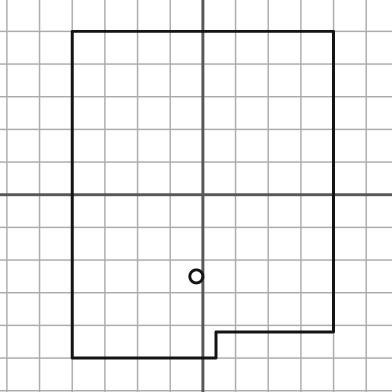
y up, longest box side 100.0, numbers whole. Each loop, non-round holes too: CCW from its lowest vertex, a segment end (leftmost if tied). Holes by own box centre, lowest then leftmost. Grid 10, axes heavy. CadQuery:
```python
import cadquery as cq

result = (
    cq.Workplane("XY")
    .moveTo(-40.0, -50.0)
    .lineTo(4.0, -50.0)
    .lineTo(4.0, -42.0)
    .lineTo(40.0, -42.0)
    .lineTo(40.0, 50.0)
    .lineTo(-40.0, 50.0)
    .close()
    .moveTo(-2.0, -25.0)
    .circle(2.0)
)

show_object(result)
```